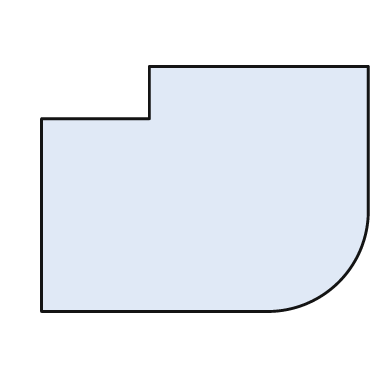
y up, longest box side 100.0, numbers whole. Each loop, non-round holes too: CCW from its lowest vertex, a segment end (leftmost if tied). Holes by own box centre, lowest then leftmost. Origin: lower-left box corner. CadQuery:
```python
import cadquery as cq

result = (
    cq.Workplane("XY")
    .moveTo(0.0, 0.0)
    .lineTo(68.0, 0.0)
    .threePointArc((91.0, 9.0), (100.0, 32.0))
    .lineTo(100.0, 75.0)
    .lineTo(33.0, 75.0)
    .lineTo(33.0, 59.0)
    .lineTo(0.0, 59.0)
    .close()
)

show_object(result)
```